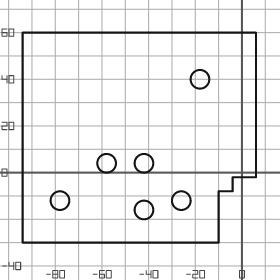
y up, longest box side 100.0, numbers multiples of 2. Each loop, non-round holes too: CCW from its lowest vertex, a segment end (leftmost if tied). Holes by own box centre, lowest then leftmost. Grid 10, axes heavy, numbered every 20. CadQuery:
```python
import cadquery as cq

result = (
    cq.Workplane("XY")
    .moveTo(-94.0, -30.0)
    .lineTo(-10.0, -30.0)
    .lineTo(-10.0, -8.0)
    .lineTo(-4.0, -8.0)
    .lineTo(-4.0, -2.0)
    .lineTo(6.0, -2.0)
    .lineTo(6.0, 60.0)
    .lineTo(-94.0, 60.0)
    .close()
    .moveTo(-42.0, -16.0)
    .circle(4.0)
    .moveTo(-78.0, -12.0)
    .circle(4.0)
    .moveTo(-26.0, -12.0)
    .circle(4.0)
    .moveTo(-58.0, 4.0)
    .circle(4.0)
    .moveTo(-42.0, 4.0)
    .circle(4.0)
    .moveTo(-18.0, 40.0)
    .circle(4.0)
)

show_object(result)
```